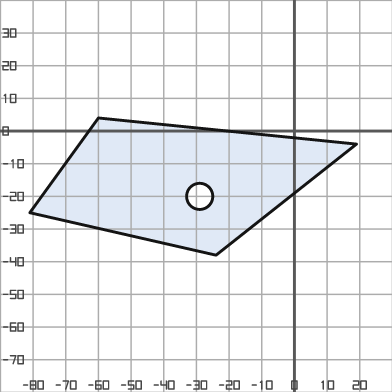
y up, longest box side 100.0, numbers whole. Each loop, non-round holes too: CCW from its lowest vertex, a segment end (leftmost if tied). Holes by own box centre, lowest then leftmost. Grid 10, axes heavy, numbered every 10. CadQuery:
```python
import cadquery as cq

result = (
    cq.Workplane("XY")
    .moveTo(-24.0, -38.0)
    .lineTo(19.0, -4.0)
    .lineTo(-60.0, 4.0)
    .lineTo(-81.0, -25.0)
    .close()
    .moveTo(-29.0, -20.0)
    .circle(4.0)
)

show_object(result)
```